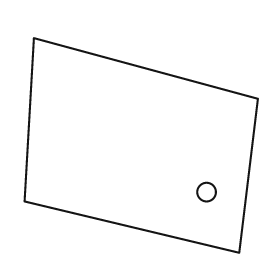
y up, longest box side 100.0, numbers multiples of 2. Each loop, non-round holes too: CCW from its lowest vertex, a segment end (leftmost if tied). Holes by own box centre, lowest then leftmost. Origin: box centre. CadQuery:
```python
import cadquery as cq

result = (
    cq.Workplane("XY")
    .moveTo(42.0, -46.0)
    .lineTo(50.0, 20.0)
    .lineTo(-46.0, 46.0)
    .lineTo(-50.0, -24.0)
    .close()
    .moveTo(28.0, -20.0)
    .circle(4.0)
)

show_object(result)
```